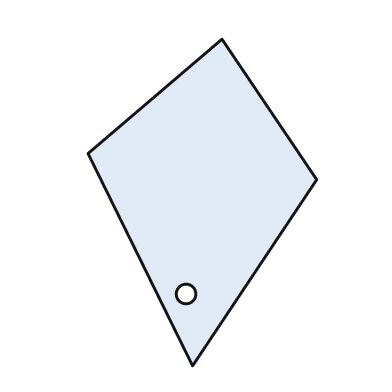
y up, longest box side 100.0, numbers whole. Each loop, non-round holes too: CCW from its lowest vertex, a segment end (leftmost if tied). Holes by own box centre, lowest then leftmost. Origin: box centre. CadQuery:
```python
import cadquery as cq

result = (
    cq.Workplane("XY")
    .moveTo(-3.0, -50.0)
    .lineTo(35.0, 7.0)
    .lineTo(6.0, 50.0)
    .lineTo(-35.0, 15.0)
    .close()
    .moveTo(-5.0, -28.0)
    .circle(3.0)
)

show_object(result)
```